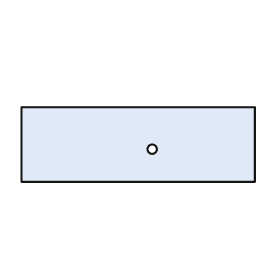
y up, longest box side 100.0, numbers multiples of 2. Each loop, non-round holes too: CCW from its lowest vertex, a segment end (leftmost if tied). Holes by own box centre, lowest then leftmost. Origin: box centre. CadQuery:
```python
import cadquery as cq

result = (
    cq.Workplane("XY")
    .moveTo(-50.0, -16.0)
    .lineTo(50.0, -16.0)
    .lineTo(50.0, 16.0)
    .lineTo(-50.0, 16.0)
    .close()
    .moveTo(6.0, -2.0)
    .circle(2.0)
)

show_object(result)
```